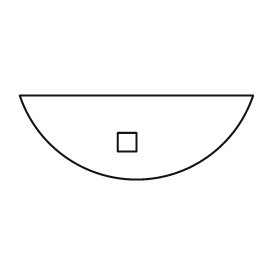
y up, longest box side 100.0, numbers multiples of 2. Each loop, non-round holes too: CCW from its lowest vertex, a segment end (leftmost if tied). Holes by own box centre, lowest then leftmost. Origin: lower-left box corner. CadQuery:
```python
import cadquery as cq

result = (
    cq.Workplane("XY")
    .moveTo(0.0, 36.0)
    .threePointArc((50.0, 0.0), (100.0, 36.0))
    .close()
    .moveTo(42.0, 12.0)
    .lineTo(50.0, 12.0)
    .lineTo(50.0, 20.0)
    .lineTo(42.0, 20.0)
    .close()
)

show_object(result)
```